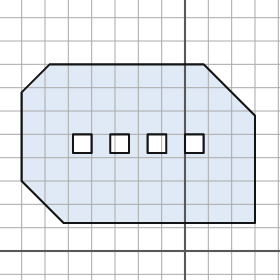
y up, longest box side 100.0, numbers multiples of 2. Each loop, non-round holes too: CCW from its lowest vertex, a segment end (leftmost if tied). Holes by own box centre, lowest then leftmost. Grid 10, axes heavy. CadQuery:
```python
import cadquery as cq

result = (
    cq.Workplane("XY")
    .moveTo(-52.0, 12.0)
    .lineTo(30.0, 12.0)
    .lineTo(30.0, 58.0)
    .lineTo(8.0, 80.0)
    .lineTo(-58.0, 80.0)
    .lineTo(-70.0, 68.0)
    .lineTo(-70.0, 30.0)
    .close()
    .moveTo(-48.0, 42.0)
    .lineTo(-40.0, 42.0)
    .lineTo(-40.0, 50.0)
    .lineTo(-48.0, 50.0)
    .close()
    .moveTo(-32.0, 42.0)
    .lineTo(-24.0, 42.0)
    .lineTo(-24.0, 50.0)
    .lineTo(-32.0, 50.0)
    .close()
    .moveTo(-16.0, 42.0)
    .lineTo(-8.0, 42.0)
    .lineTo(-8.0, 50.0)
    .lineTo(-16.0, 50.0)
    .close()
    .moveTo(0.0, 42.0)
    .lineTo(8.0, 42.0)
    .lineTo(8.0, 50.0)
    .lineTo(0.0, 50.0)
    .close()
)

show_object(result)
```